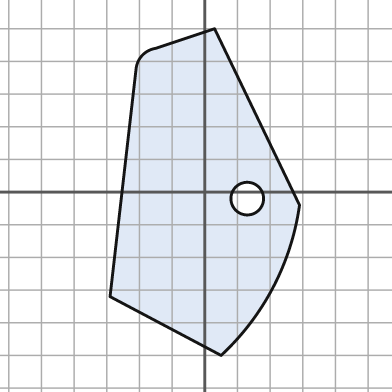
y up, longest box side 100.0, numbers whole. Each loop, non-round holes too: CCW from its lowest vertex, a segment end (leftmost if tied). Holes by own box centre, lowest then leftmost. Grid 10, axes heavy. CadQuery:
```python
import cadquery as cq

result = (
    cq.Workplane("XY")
    .moveTo(5.0, -50.0)
    .threePointArc((21.0, -29.0), (29.0, -4.0))
    .lineTo(3.0, 50.0)
    .lineTo(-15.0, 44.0)
    .threePointArc((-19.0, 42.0), (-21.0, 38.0))
    .lineTo(-29.0, -32.0)
    .close()
    .moveTo(13.0, -2.0)
    .circle(5.0)
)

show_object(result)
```